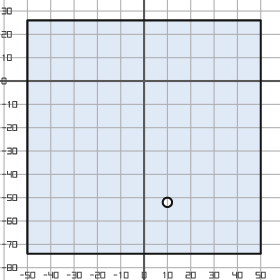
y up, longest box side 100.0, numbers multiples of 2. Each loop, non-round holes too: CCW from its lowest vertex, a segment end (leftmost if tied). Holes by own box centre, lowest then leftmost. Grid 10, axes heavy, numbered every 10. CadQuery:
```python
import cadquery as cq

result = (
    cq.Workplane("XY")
    .moveTo(-50.0, -74.0)
    .lineTo(50.0, -74.0)
    .lineTo(50.0, 26.0)
    .lineTo(-50.0, 26.0)
    .close()
    .moveTo(10.0, -52.0)
    .circle(2.0)
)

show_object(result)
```